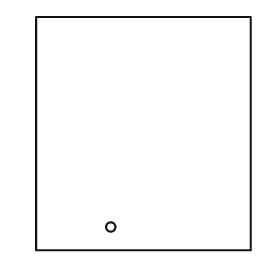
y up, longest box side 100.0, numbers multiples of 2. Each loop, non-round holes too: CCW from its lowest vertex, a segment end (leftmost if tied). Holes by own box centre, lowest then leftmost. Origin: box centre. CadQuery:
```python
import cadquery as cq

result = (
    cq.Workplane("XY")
    .moveTo(-46.0, -50.0)
    .lineTo(46.0, -50.0)
    .lineTo(46.0, 50.0)
    .lineTo(-46.0, 50.0)
    .close()
    .moveTo(-14.0, -40.0)
    .circle(2.0)
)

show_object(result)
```